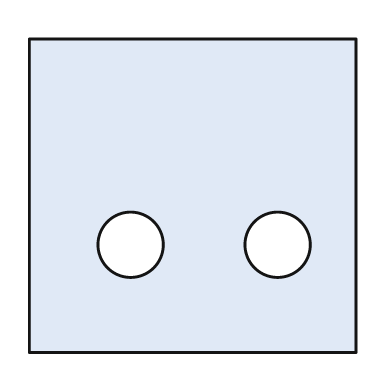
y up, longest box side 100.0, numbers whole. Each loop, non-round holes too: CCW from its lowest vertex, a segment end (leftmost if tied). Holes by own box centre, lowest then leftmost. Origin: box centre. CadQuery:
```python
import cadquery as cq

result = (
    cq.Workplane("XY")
    .moveTo(-50.0, -48.0)
    .lineTo(50.0, -48.0)
    .lineTo(50.0, 48.0)
    .lineTo(-50.0, 48.0)
    .close()
    .moveTo(-19.0, -15.0)
    .circle(10.0)
    .moveTo(26.0, -15.0)
    .circle(10.0)
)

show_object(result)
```